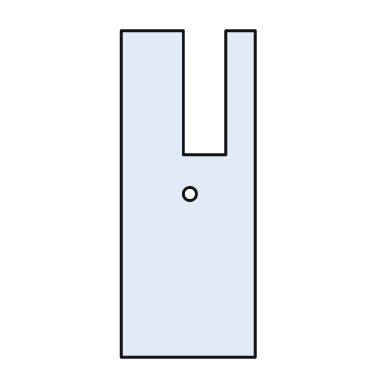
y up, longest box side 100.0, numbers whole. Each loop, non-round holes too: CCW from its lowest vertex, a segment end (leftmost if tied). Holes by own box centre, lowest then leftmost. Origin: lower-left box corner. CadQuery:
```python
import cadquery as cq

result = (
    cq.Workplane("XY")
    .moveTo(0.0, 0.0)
    .lineTo(41.0, 0.0)
    .lineTo(41.0, 100.0)
    .lineTo(32.0, 100.0)
    .lineTo(32.0, 62.0)
    .lineTo(19.0, 62.0)
    .lineTo(19.0, 100.0)
    .lineTo(0.0, 100.0)
    .close()
    .moveTo(21.0, 50.0)
    .circle(2.0)
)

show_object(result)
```